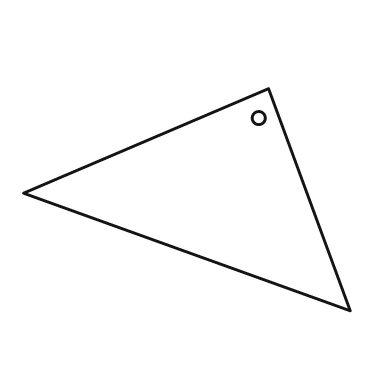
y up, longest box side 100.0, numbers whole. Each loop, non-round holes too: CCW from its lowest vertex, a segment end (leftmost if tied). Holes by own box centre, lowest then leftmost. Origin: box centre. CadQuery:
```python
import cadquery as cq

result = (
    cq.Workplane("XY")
    .moveTo(50.0, -34.0)
    .lineTo(25.0, 34.0)
    .lineTo(-50.0, 2.0)
    .close()
    .moveTo(22.0, 25.0)
    .circle(2.0)
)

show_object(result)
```